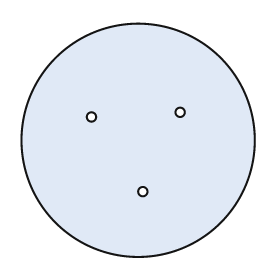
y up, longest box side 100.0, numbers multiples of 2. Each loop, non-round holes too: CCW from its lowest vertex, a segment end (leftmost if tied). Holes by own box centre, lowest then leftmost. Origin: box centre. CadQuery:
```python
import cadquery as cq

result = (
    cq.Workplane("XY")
    .moveTo(0.0, 0.0)
    .circle(50.0)
    .moveTo(2.0, -22.0)
    .circle(2.0)
    .moveTo(-20.0, 10.0)
    .circle(2.0)
    .moveTo(18.0, 12.0)
    .circle(2.0)
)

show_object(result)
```